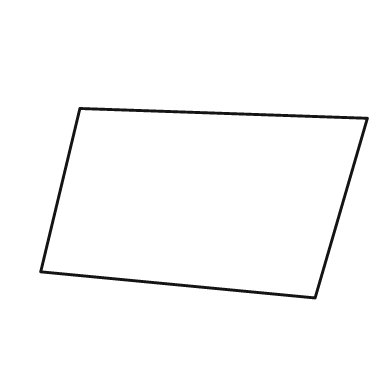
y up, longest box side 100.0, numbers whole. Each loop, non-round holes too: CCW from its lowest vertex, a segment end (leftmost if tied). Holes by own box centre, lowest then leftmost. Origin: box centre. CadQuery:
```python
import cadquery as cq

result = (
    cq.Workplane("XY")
    .moveTo(34.0, -29.0)
    .lineTo(50.0, 26.0)
    .lineTo(-38.0, 29.0)
    .lineTo(-50.0, -21.0)
    .close()
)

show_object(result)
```